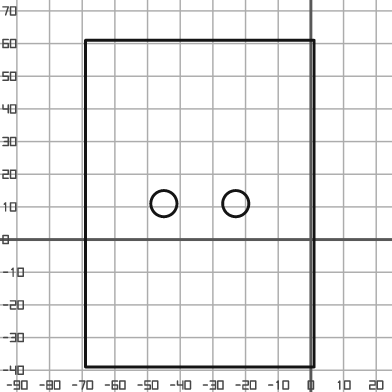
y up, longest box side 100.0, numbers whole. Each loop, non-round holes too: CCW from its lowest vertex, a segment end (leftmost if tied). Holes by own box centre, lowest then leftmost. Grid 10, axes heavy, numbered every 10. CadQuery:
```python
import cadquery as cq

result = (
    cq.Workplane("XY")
    .moveTo(-69.0, -39.0)
    .lineTo(1.0, -39.0)
    .lineTo(1.0, 61.0)
    .lineTo(-69.0, 61.0)
    .close()
    .moveTo(-45.0, 11.0)
    .circle(4.0)
    .moveTo(-23.0, 11.0)
    .circle(4.0)
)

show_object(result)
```